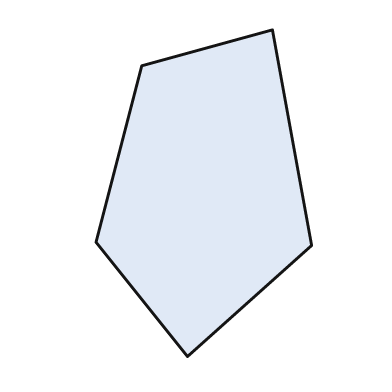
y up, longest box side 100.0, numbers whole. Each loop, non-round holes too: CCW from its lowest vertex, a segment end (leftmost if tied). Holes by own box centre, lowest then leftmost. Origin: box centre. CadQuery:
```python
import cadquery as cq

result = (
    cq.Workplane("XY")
    .moveTo(-5.0, -50.0)
    .lineTo(33.0, -16.0)
    .lineTo(21.0, 50.0)
    .lineTo(-19.0, 39.0)
    .lineTo(-33.0, -15.0)
    .close()
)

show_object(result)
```